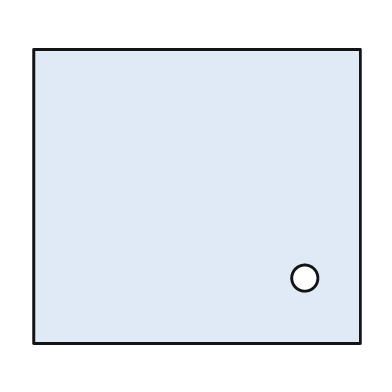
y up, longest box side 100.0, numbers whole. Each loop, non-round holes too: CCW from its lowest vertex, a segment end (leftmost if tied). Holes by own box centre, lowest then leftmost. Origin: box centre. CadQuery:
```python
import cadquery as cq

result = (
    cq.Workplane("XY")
    .moveTo(-50.0, -45.0)
    .lineTo(50.0, -45.0)
    .lineTo(50.0, 45.0)
    .lineTo(-50.0, 45.0)
    .close()
    .moveTo(33.0, -25.0)
    .circle(4.0)
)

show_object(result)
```